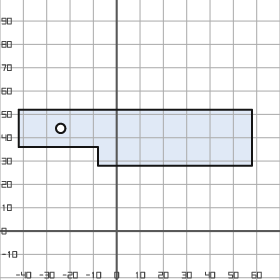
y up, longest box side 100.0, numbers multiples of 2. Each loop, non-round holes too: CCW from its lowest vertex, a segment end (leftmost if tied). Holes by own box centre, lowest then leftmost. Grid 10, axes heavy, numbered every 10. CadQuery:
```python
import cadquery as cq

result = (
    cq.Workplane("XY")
    .moveTo(-8.0, 28.0)
    .lineTo(58.0, 28.0)
    .lineTo(58.0, 52.0)
    .lineTo(-42.0, 52.0)
    .lineTo(-42.0, 36.0)
    .lineTo(-8.0, 36.0)
    .close()
    .moveTo(-24.0, 44.0)
    .circle(2.0)
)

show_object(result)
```